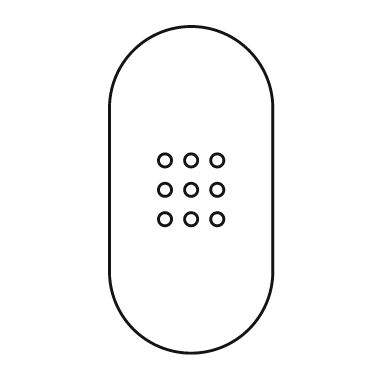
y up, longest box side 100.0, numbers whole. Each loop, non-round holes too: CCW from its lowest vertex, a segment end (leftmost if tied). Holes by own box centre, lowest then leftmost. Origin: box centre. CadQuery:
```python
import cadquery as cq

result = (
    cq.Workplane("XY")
    .moveTo(-25.0, -25.0)
    .threePointArc((0.0, -50.0), (25.0, -25.0))
    .lineTo(25.0, 25.0)
    .threePointArc((0.0, 50.0), (-25.0, 25.0))
    .close()
    .moveTo(-8.0, -9.0)
    .circle(2.0)
    .moveTo(0.0, -9.0)
    .circle(2.0)
    .moveTo(8.0, -9.0)
    .circle(2.0)
    .moveTo(-8.0, 0.0)
    .circle(2.0)
    .moveTo(0.0, 0.0)
    .circle(2.0)
    .moveTo(8.0, 0.0)
    .circle(2.0)
    .moveTo(-8.0, 9.0)
    .circle(2.0)
    .moveTo(0.0, 9.0)
    .circle(2.0)
    .moveTo(8.0, 9.0)
    .circle(2.0)
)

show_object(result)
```